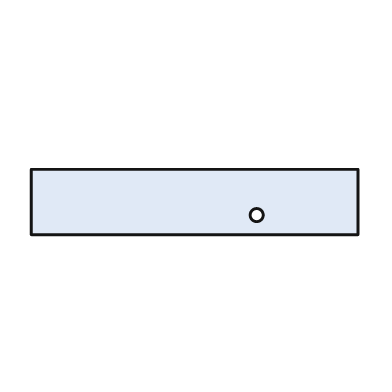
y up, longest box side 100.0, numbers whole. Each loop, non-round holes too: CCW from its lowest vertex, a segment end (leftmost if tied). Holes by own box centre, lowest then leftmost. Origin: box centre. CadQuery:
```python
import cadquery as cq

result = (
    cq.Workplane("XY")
    .moveTo(-50.0, -10.0)
    .lineTo(50.0, -10.0)
    .lineTo(50.0, 10.0)
    .lineTo(-50.0, 10.0)
    .close()
    .moveTo(19.0, -4.0)
    .circle(2.0)
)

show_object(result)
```